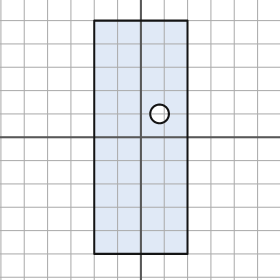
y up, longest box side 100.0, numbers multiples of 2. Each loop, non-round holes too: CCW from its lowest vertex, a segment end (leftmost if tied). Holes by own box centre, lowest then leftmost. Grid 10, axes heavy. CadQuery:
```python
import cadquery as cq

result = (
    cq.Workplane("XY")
    .moveTo(-20.0, -50.0)
    .lineTo(20.0, -50.0)
    .lineTo(20.0, 50.0)
    .lineTo(-20.0, 50.0)
    .close()
    .moveTo(8.0, 10.0)
    .circle(4.0)
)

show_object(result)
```